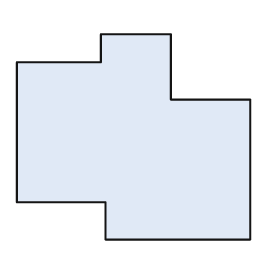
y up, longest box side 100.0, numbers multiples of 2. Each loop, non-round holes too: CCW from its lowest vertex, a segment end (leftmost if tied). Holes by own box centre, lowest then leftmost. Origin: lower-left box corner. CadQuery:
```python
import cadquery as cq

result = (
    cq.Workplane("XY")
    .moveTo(38.0, 0.0)
    .lineTo(100.0, 0.0)
    .lineTo(100.0, 60.0)
    .lineTo(66.0, 60.0)
    .lineTo(66.0, 88.0)
    .lineTo(36.0, 88.0)
    .lineTo(36.0, 76.0)
    .lineTo(0.0, 76.0)
    .lineTo(0.0, 16.0)
    .lineTo(38.0, 16.0)
    .close()
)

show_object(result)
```